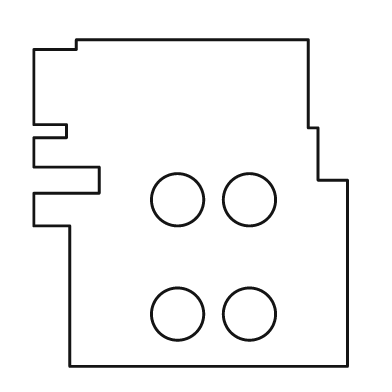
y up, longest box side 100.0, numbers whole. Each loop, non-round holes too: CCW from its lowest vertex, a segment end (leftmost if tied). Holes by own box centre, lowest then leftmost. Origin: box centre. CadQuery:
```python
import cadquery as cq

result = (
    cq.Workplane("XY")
    .moveTo(-37.0, -50.0)
    .lineTo(48.0, -50.0)
    .lineTo(48.0, 7.0)
    .lineTo(39.0, 7.0)
    .lineTo(39.0, 23.0)
    .lineTo(36.0, 23.0)
    .lineTo(36.0, 50.0)
    .lineTo(-35.0, 50.0)
    .lineTo(-35.0, 47.0)
    .lineTo(-48.0, 47.0)
    .lineTo(-48.0, 24.0)
    .lineTo(-38.0, 24.0)
    .lineTo(-38.0, 20.0)
    .lineTo(-48.0, 20.0)
    .lineTo(-48.0, 11.0)
    .lineTo(-28.0, 11.0)
    .lineTo(-28.0, 3.0)
    .lineTo(-48.0, 3.0)
    .lineTo(-48.0, -7.0)
    .lineTo(-37.0, -7.0)
    .close()
    .moveTo(-4.0, -34.0)
    .circle(8.0)
    .moveTo(18.0, -34.0)
    .circle(8.0)
    .moveTo(-4.0, 1.0)
    .circle(8.0)
    .moveTo(18.0, 1.0)
    .circle(8.0)
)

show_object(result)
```